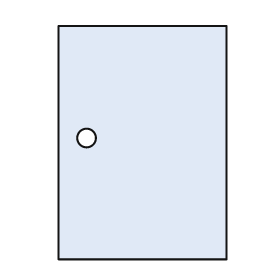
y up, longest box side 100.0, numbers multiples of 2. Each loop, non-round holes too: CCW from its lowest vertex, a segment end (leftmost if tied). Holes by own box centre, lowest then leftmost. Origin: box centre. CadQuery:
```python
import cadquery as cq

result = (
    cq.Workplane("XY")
    .moveTo(-36.0, -50.0)
    .lineTo(36.0, -50.0)
    .lineTo(36.0, 50.0)
    .lineTo(-36.0, 50.0)
    .close()
    .moveTo(-24.0, 2.0)
    .circle(4.0)
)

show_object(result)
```